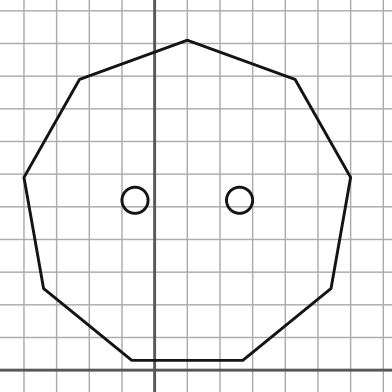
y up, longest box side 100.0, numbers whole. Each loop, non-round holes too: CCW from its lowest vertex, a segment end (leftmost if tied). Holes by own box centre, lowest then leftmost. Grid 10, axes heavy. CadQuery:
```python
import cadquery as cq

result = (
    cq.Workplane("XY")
    .moveTo(-7.0, 3.0)
    .lineTo(27.0, 3.0)
    .lineTo(54.0, 25.0)
    .lineTo(60.0, 59.0)
    .lineTo(43.0, 89.0)
    .lineTo(10.0, 101.0)
    .lineTo(-23.0, 89.0)
    .lineTo(-40.0, 59.0)
    .lineTo(-34.0, 25.0)
    .close()
    .moveTo(-6.0, 52.0)
    .circle(4.0)
    .moveTo(26.0, 52.0)
    .circle(4.0)
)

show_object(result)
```